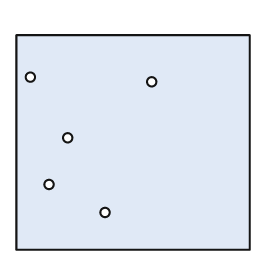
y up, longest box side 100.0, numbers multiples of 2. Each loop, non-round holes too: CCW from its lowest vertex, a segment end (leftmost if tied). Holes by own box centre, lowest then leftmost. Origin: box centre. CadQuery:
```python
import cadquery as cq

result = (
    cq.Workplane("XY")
    .moveTo(-50.0, -46.0)
    .lineTo(50.0, -46.0)
    .lineTo(50.0, 46.0)
    .lineTo(-50.0, 46.0)
    .close()
    .moveTo(-12.0, -30.0)
    .circle(2.0)
    .moveTo(-36.0, -18.0)
    .circle(2.0)
    .moveTo(-28.0, 2.0)
    .circle(2.0)
    .moveTo(8.0, 26.0)
    .circle(2.0)
    .moveTo(-44.0, 28.0)
    .circle(2.0)
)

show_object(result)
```